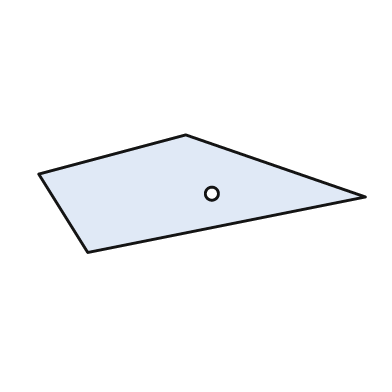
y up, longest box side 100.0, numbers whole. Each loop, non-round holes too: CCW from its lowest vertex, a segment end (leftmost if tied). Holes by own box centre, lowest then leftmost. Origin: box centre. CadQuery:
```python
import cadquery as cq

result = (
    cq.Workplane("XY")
    .moveTo(-35.0, -18.0)
    .lineTo(50.0, -1.0)
    .lineTo(-5.0, 18.0)
    .lineTo(-50.0, 6.0)
    .close()
    .moveTo(3.0, 0.0)
    .circle(2.0)
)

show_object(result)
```